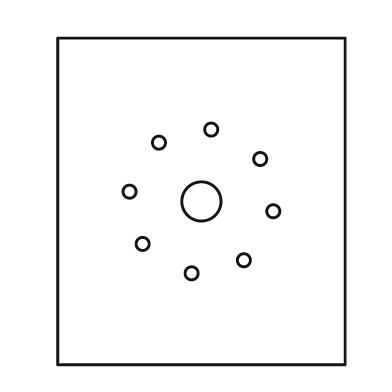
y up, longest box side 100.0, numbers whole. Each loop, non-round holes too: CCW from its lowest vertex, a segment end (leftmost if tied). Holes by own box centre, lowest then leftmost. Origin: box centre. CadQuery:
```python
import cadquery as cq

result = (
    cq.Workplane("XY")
    .moveTo(-44.0, -50.0)
    .lineTo(44.0, -50.0)
    .lineTo(44.0, 50.0)
    .lineTo(-44.0, 50.0)
    .close()
    .moveTo(-3.0, -22.0)
    .circle(2.0)
    .moveTo(13.0, -18.0)
    .circle(2.0)
    .moveTo(-18.0, -13.0)
    .circle(2.0)
    .moveTo(22.0, -3.0)
    .circle(2.0)
    .moveTo(0.0, 0.0)
    .circle(6.0)
    .moveTo(-22.0, 3.0)
    .circle(2.0)
    .moveTo(18.0, 13.0)
    .circle(2.0)
    .moveTo(-13.0, 18.0)
    .circle(2.0)
    .moveTo(3.0, 22.0)
    .circle(2.0)
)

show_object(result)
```